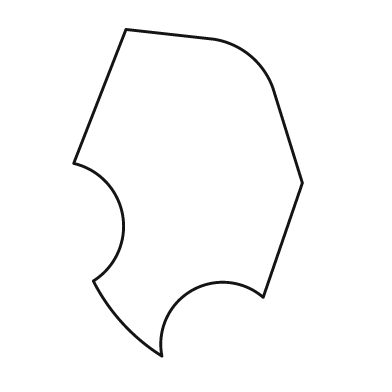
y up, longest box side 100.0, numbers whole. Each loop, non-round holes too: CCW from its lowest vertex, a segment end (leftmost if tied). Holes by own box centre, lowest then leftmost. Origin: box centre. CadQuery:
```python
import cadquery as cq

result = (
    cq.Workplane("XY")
    .moveTo(-8.0, -50.0)
    .threePointArc((1.0, -30.0), (23.0, -32.0))
    .lineTo(35.0, 3.0)
    .lineTo(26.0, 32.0)
    .threePointArc((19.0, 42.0), (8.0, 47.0))
    .lineTo(-19.0, 50.0)
    .lineTo(-35.0, 9.0)
    .threePointArc((-20.0, -7.0), (-29.0, -27.0))
    .threePointArc((-20.0, -40.0), (-8.0, -50.0))
    .close()
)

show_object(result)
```